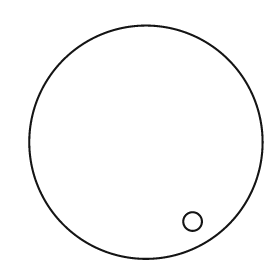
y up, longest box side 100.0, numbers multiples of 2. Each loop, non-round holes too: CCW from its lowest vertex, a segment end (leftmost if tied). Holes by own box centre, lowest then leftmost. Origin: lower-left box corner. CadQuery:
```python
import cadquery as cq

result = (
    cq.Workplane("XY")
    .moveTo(50.0, 50.0)
    .circle(50.0)
    .moveTo(70.0, 16.0)
    .circle(4.0)
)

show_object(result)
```